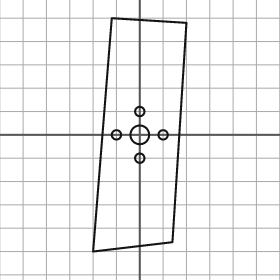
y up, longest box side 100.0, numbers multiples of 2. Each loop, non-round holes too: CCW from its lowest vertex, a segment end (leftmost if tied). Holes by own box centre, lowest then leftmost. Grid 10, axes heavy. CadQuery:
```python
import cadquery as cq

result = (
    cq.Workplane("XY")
    .moveTo(-20.0, -50.0)
    .lineTo(14.0, -46.0)
    .lineTo(20.0, 48.0)
    .lineTo(-12.0, 50.0)
    .close()
    .moveTo(0.0, -10.0)
    .circle(2.0)
    .moveTo(-10.0, 0.0)
    .circle(2.0)
    .moveTo(0.0, 0.0)
    .circle(4.0)
    .moveTo(10.0, 0.0)
    .circle(2.0)
    .moveTo(0.0, 10.0)
    .circle(2.0)
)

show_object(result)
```